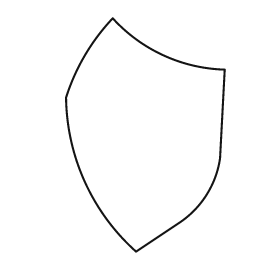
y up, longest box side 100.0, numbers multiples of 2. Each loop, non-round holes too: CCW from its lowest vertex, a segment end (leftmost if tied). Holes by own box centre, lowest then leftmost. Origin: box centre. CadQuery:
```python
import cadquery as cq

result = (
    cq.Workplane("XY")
    .moveTo(-4.0, -50.0)
    .lineTo(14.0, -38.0)
    .threePointArc((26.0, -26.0), (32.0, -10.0))
    .lineTo(34.0, 28.0)
    .threePointArc((8.0, 34.0), (-14.0, 50.0))
    .threePointArc((-26.0, 34.0), (-34.0, 16.0))
    .threePointArc((-26.0, -20.0), (-4.0, -50.0))
    .close()
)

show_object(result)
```